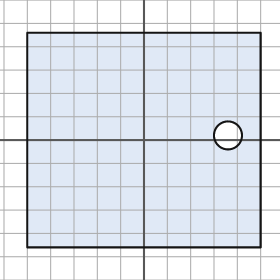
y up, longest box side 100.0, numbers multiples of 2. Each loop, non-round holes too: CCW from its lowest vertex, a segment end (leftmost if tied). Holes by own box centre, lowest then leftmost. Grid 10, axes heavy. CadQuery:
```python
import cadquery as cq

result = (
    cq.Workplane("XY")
    .moveTo(-50.0, -46.0)
    .lineTo(50.0, -46.0)
    .lineTo(50.0, 46.0)
    .lineTo(-50.0, 46.0)
    .close()
    .moveTo(36.0, 2.0)
    .circle(6.0)
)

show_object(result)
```